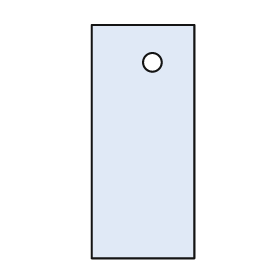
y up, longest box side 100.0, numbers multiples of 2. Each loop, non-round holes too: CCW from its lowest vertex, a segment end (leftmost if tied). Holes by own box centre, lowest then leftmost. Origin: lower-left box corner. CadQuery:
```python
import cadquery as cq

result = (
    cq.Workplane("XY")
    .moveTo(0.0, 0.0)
    .lineTo(44.0, 0.0)
    .lineTo(44.0, 100.0)
    .lineTo(0.0, 100.0)
    .close()
    .moveTo(26.0, 84.0)
    .circle(4.0)
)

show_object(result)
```